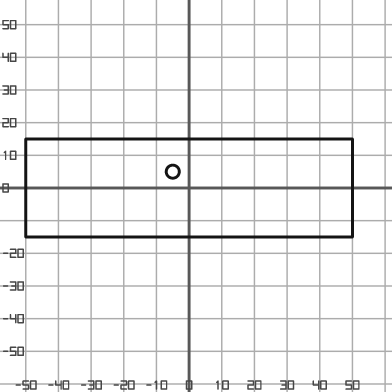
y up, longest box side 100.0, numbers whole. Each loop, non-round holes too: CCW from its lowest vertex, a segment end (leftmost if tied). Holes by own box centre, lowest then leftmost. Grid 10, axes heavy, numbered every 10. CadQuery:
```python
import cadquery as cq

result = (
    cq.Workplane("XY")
    .moveTo(-50.0, -15.0)
    .lineTo(50.0, -15.0)
    .lineTo(50.0, 15.0)
    .lineTo(-50.0, 15.0)
    .close()
    .moveTo(-5.0, 5.0)
    .circle(2.0)
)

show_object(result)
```